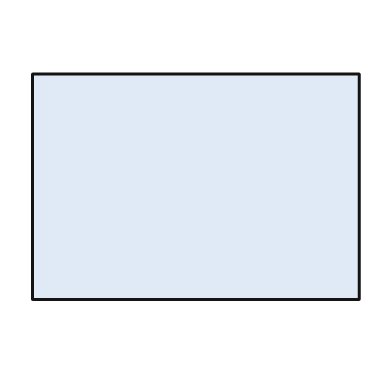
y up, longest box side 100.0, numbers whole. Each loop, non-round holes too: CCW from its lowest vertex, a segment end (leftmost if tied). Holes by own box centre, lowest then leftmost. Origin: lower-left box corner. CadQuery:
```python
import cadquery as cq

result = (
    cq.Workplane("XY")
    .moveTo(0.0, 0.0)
    .lineTo(100.0, 0.0)
    .lineTo(100.0, 69.0)
    .lineTo(0.0, 69.0)
    .close()
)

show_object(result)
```